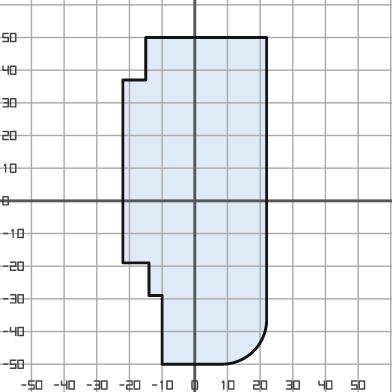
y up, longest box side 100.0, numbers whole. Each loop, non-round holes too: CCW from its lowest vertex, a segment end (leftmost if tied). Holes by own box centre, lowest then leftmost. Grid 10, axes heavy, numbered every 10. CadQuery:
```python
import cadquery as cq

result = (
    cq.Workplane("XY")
    .moveTo(-10.0, -50.0)
    .lineTo(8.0, -50.0)
    .threePointArc((18.0, -46.0), (22.0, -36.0))
    .lineTo(22.0, 50.0)
    .lineTo(-15.0, 50.0)
    .lineTo(-15.0, 37.0)
    .lineTo(-22.0, 37.0)
    .lineTo(-22.0, -19.0)
    .lineTo(-14.0, -19.0)
    .lineTo(-14.0, -29.0)
    .lineTo(-10.0, -29.0)
    .close()
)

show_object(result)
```